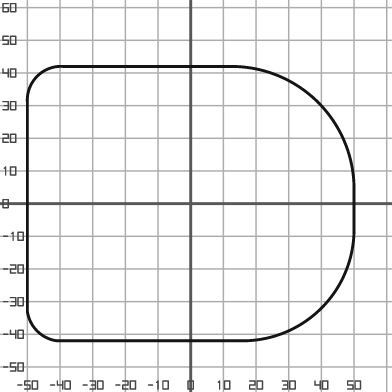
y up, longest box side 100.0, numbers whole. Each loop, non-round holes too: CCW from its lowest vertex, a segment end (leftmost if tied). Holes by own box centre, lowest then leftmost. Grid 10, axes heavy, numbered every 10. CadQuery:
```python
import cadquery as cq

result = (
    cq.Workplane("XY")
    .moveTo(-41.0, -42.0)
    .lineTo(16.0, -42.0)
    .threePointArc((40.0, -32.0), (50.0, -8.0))
    .lineTo(50.0, 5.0)
    .threePointArc((39.0, 31.0), (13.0, 42.0))
    .lineTo(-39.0, 42.0)
    .threePointArc((-47.0, 39.0), (-50.0, 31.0))
    .lineTo(-50.0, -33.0)
    .threePointArc((-47.0, -39.0), (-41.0, -42.0))
    .close()
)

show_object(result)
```